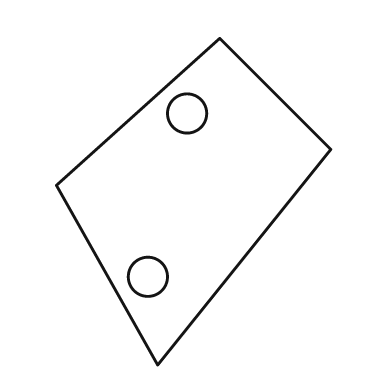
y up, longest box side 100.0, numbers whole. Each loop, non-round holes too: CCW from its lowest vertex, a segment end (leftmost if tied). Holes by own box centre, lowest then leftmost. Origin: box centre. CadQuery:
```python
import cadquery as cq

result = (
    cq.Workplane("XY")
    .moveTo(-11.0, -50.0)
    .lineTo(42.0, 16.0)
    .lineTo(8.0, 50.0)
    .lineTo(-42.0, 5.0)
    .close()
    .moveTo(-14.0, -23.0)
    .circle(6.0)
    .moveTo(-2.0, 27.0)
    .circle(6.0)
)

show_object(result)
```